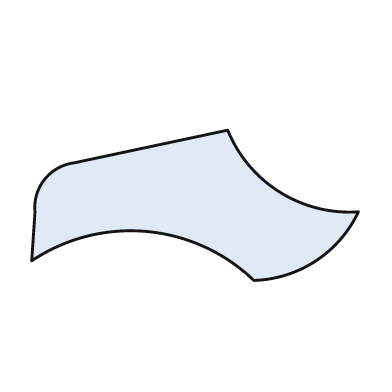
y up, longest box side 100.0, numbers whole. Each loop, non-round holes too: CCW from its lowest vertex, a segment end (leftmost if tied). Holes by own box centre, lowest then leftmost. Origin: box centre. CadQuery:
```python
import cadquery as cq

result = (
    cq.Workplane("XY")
    .moveTo(18.0, -23.0)
    .threePointArc((37.0, -17.0), (50.0, -2.0))
    .threePointArc((26.0, 4.0), (10.0, 23.0))
    .lineTo(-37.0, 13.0)
    .threePointArc((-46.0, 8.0), (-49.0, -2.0))
    .lineTo(-50.0, -17.0)
    .threePointArc((-15.0, -8.0), (18.0, -23.0))
    .close()
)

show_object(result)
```